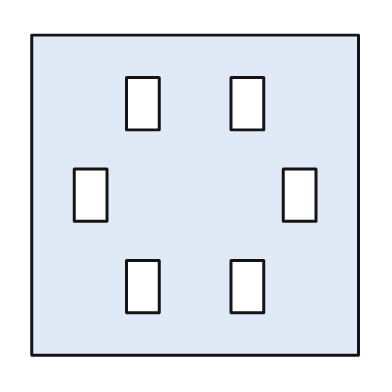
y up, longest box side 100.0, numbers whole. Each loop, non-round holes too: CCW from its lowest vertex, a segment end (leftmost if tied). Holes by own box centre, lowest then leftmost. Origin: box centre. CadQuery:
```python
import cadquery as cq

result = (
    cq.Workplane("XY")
    .moveTo(-50.0, -49.0)
    .lineTo(50.0, -49.0)
    .lineTo(50.0, 49.0)
    .lineTo(-50.0, 49.0)
    .close()
    .moveTo(-21.0, -36.0)
    .lineTo(-11.0, -36.0)
    .lineTo(-11.0, -20.0)
    .lineTo(-21.0, -20.0)
    .close()
    .moveTo(11.0, -36.0)
    .lineTo(21.0, -36.0)
    .lineTo(21.0, -20.0)
    .lineTo(11.0, -20.0)
    .close()
    .moveTo(-37.0, -8.0)
    .lineTo(-27.0, -8.0)
    .lineTo(-27.0, 8.0)
    .lineTo(-37.0, 8.0)
    .close()
    .moveTo(27.0, -8.0)
    .lineTo(37.0, -8.0)
    .lineTo(37.0, 8.0)
    .lineTo(27.0, 8.0)
    .close()
    .moveTo(-21.0, 20.0)
    .lineTo(-11.0, 20.0)
    .lineTo(-11.0, 36.0)
    .lineTo(-21.0, 36.0)
    .close()
    .moveTo(11.0, 20.0)
    .lineTo(21.0, 20.0)
    .lineTo(21.0, 36.0)
    .lineTo(11.0, 36.0)
    .close()
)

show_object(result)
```